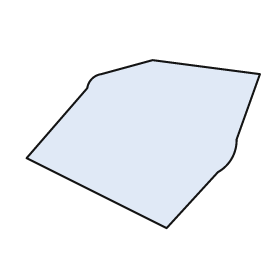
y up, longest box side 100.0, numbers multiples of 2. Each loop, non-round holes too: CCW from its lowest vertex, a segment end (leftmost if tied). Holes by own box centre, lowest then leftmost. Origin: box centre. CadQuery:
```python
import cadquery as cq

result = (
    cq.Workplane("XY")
    .moveTo(10.0, -36.0)
    .lineTo(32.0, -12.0)
    .threePointArc((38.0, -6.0), (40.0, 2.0))
    .lineTo(50.0, 30.0)
    .lineTo(4.0, 36.0)
    .lineTo(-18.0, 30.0)
    .threePointArc((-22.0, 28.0), (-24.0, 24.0))
    .lineTo(-50.0, -6.0)
    .close()
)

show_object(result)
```